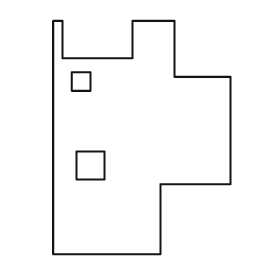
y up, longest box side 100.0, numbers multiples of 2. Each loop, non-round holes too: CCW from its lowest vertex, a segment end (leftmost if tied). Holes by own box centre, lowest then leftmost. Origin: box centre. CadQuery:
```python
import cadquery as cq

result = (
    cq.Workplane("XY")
    .moveTo(-38.0, -50.0)
    .lineTo(8.0, -50.0)
    .lineTo(8.0, -20.0)
    .lineTo(38.0, -20.0)
    .lineTo(38.0, 26.0)
    .lineTo(14.0, 26.0)
    .lineTo(14.0, 50.0)
    .lineTo(-4.0, 50.0)
    .lineTo(-4.0, 34.0)
    .lineTo(-34.0, 34.0)
    .lineTo(-34.0, 50.0)
    .lineTo(-38.0, 50.0)
    .close()
    .moveTo(-28.0, -18.0)
    .lineTo(-16.0, -18.0)
    .lineTo(-16.0, -6.0)
    .lineTo(-28.0, -6.0)
    .close()
    .moveTo(-30.0, 20.0)
    .lineTo(-22.0, 20.0)
    .lineTo(-22.0, 28.0)
    .lineTo(-30.0, 28.0)
    .close()
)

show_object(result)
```